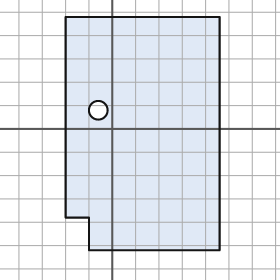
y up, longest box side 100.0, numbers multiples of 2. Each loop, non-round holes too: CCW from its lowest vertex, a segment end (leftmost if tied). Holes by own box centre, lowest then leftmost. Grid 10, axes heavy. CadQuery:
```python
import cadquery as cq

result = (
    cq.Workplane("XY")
    .moveTo(-10.0, -52.0)
    .lineTo(46.0, -52.0)
    .lineTo(46.0, 48.0)
    .lineTo(-20.0, 48.0)
    .lineTo(-20.0, -38.0)
    .lineTo(-10.0, -38.0)
    .close()
    .moveTo(-6.0, 8.0)
    .circle(4.0)
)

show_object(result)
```